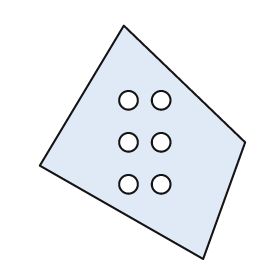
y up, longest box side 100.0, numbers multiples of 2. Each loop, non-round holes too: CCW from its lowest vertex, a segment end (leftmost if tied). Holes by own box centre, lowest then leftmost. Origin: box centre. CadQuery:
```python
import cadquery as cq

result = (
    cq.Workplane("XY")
    .moveTo(26.0, -50.0)
    .lineTo(44.0, 0.0)
    .lineTo(-8.0, 50.0)
    .lineTo(-44.0, -10.0)
    .close()
    .moveTo(-6.0, -18.0)
    .circle(4.0)
    .moveTo(8.0, -18.0)
    .circle(4.0)
    .moveTo(-6.0, 0.0)
    .circle(4.0)
    .moveTo(8.0, 0.0)
    .circle(4.0)
    .moveTo(-6.0, 18.0)
    .circle(4.0)
    .moveTo(8.0, 18.0)
    .circle(4.0)
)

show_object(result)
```